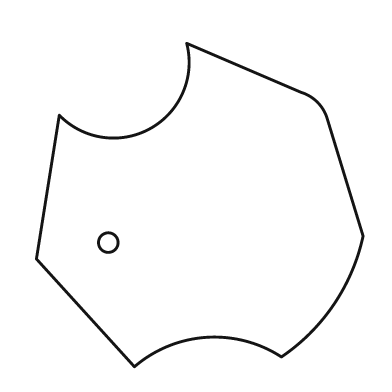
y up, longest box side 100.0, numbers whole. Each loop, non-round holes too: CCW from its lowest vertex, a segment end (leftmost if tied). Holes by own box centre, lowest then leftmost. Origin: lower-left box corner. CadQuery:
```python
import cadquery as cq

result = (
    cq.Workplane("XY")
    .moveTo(30.0, 0.0)
    .threePointArc((52.0, 9.0), (75.0, 3.0))
    .threePointArc((91.0, 19.0), (100.0, 40.0))
    .lineTo(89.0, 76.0)
    .threePointArc((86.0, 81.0), (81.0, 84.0))
    .lineTo(46.0, 99.0)
    .threePointArc((35.0, 73.0), (7.0, 77.0))
    .lineTo(0.0, 33.0)
    .close()
    .moveTo(22.0, 38.0)
    .circle(3.0)
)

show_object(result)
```